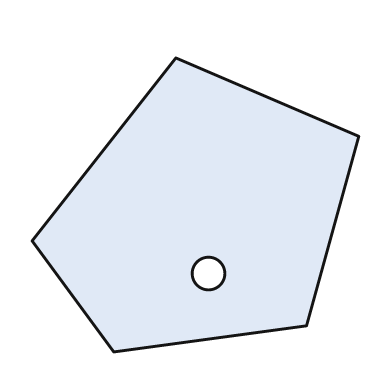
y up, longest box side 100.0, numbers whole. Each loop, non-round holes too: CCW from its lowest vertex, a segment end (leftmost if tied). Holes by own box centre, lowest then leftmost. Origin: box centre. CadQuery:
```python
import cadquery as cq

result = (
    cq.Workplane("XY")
    .moveTo(-25.0, -45.0)
    .lineTo(34.0, -37.0)
    .lineTo(50.0, 21.0)
    .lineTo(-6.0, 45.0)
    .lineTo(-50.0, -11.0)
    .close()
    .moveTo(4.0, -21.0)
    .circle(5.0)
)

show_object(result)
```